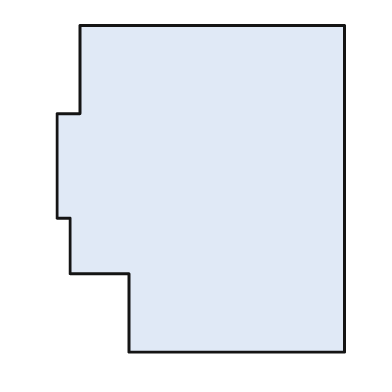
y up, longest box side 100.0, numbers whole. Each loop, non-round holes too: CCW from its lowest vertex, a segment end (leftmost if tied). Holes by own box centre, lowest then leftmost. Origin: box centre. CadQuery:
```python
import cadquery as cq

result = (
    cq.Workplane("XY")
    .moveTo(-22.0, -50.0)
    .lineTo(44.0, -50.0)
    .lineTo(44.0, 50.0)
    .lineTo(-37.0, 50.0)
    .lineTo(-37.0, 23.0)
    .lineTo(-44.0, 23.0)
    .lineTo(-44.0, -9.0)
    .lineTo(-40.0, -9.0)
    .lineTo(-40.0, -26.0)
    .lineTo(-22.0, -26.0)
    .close()
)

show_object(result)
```